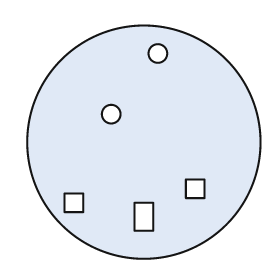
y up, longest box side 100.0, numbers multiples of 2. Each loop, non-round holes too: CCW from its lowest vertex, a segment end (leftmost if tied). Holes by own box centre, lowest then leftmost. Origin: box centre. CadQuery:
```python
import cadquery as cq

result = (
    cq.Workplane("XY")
    .moveTo(0.0, 0.0)
    .circle(50.0)
    .moveTo(-4.0, -38.0)
    .lineTo(4.0, -38.0)
    .lineTo(4.0, -26.0)
    .lineTo(-4.0, -26.0)
    .close()
    .moveTo(-34.0, -30.0)
    .lineTo(-26.0, -30.0)
    .lineTo(-26.0, -22.0)
    .lineTo(-34.0, -22.0)
    .close()
    .moveTo(18.0, -24.0)
    .lineTo(26.0, -24.0)
    .lineTo(26.0, -16.0)
    .lineTo(18.0, -16.0)
    .close()
    .moveTo(-14.0, 12.0)
    .circle(4.0)
    .moveTo(6.0, 38.0)
    .circle(4.0)
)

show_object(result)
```